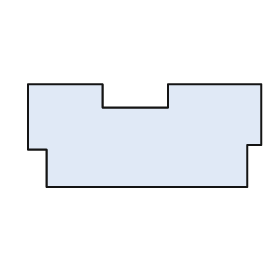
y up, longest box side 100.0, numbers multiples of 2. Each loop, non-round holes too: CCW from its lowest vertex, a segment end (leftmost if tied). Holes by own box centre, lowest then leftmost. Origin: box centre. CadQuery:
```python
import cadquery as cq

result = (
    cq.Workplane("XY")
    .moveTo(-42.0, -22.0)
    .lineTo(44.0, -22.0)
    .lineTo(44.0, -4.0)
    .lineTo(50.0, -4.0)
    .lineTo(50.0, 22.0)
    .lineTo(10.0, 22.0)
    .lineTo(10.0, 12.0)
    .lineTo(-18.0, 12.0)
    .lineTo(-18.0, 22.0)
    .lineTo(-50.0, 22.0)
    .lineTo(-50.0, -6.0)
    .lineTo(-42.0, -6.0)
    .close()
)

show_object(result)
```